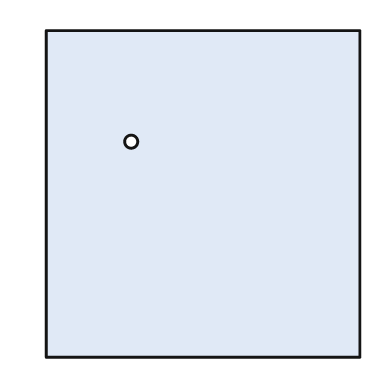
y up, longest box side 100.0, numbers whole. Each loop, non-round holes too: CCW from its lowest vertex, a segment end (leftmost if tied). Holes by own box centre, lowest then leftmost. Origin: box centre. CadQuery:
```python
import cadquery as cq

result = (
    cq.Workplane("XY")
    .moveTo(-48.0, -50.0)
    .lineTo(48.0, -50.0)
    .lineTo(48.0, 50.0)
    .lineTo(-48.0, 50.0)
    .close()
    .moveTo(-22.0, 16.0)
    .circle(2.0)
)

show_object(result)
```